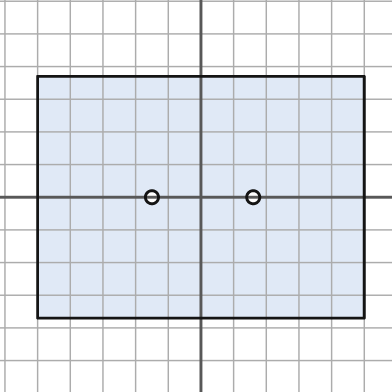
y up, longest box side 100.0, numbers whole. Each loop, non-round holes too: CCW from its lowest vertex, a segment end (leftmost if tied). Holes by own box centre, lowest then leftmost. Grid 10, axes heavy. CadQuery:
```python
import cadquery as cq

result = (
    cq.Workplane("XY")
    .moveTo(-50.0, -37.0)
    .lineTo(50.0, -37.0)
    .lineTo(50.0, 37.0)
    .lineTo(-50.0, 37.0)
    .close()
    .moveTo(-15.0, 0.0)
    .circle(2.0)
    .moveTo(16.0, 0.0)
    .circle(2.0)
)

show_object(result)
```